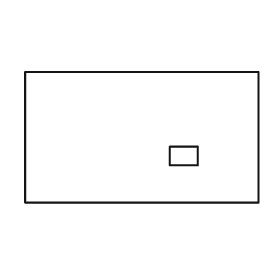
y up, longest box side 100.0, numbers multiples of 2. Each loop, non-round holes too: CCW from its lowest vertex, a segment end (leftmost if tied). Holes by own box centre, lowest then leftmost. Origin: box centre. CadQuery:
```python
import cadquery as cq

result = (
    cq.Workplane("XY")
    .moveTo(-50.0, -28.0)
    .lineTo(50.0, -28.0)
    .lineTo(50.0, 28.0)
    .lineTo(-50.0, 28.0)
    .close()
    .moveTo(12.0, -12.0)
    .lineTo(24.0, -12.0)
    .lineTo(24.0, -4.0)
    .lineTo(12.0, -4.0)
    .close()
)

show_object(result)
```